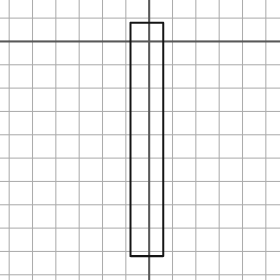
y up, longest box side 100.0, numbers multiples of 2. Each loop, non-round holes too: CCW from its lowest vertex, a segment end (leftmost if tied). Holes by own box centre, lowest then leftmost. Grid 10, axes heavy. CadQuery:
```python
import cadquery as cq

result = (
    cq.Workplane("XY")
    .moveTo(-8.0, -92.0)
    .lineTo(6.0, -92.0)
    .lineTo(6.0, 8.0)
    .lineTo(-8.0, 8.0)
    .close()
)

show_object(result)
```